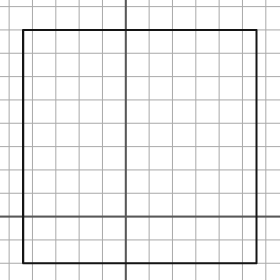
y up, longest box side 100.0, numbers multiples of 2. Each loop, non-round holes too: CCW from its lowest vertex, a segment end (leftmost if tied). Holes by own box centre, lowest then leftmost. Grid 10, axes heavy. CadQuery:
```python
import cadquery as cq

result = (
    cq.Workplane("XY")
    .moveTo(-44.0, -20.0)
    .lineTo(56.0, -20.0)
    .lineTo(56.0, 80.0)
    .lineTo(-44.0, 80.0)
    .close()
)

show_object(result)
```